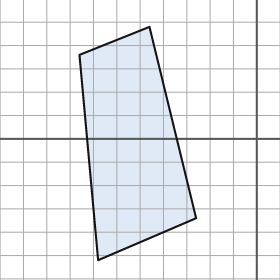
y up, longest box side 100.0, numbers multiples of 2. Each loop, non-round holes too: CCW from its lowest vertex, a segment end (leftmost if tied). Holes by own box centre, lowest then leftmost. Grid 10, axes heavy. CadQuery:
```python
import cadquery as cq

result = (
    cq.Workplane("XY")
    .moveTo(-68.0, -52.0)
    .lineTo(-26.0, -34.0)
    .lineTo(-46.0, 48.0)
    .lineTo(-76.0, 36.0)
    .close()
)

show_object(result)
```